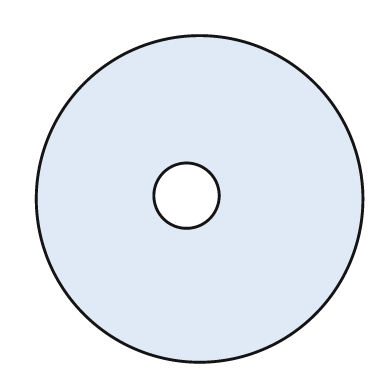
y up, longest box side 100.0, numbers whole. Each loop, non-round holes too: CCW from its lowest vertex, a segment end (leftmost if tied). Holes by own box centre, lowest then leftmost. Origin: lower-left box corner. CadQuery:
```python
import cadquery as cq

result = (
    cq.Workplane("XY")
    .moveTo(50.0, 50.0)
    .circle(50.0)
    .moveTo(46.0, 51.0)
    .circle(10.0)
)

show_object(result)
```